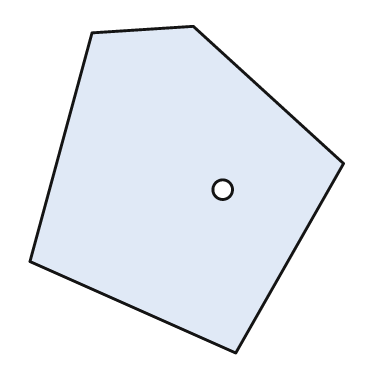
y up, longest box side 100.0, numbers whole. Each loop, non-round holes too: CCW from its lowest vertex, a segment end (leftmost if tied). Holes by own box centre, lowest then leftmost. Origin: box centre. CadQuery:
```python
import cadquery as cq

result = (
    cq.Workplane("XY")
    .moveTo(15.0, -50.0)
    .lineTo(48.0, 8.0)
    .lineTo(2.0, 50.0)
    .lineTo(-29.0, 48.0)
    .lineTo(-48.0, -22.0)
    .close()
    .moveTo(11.0, 0.0)
    .circle(3.0)
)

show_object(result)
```